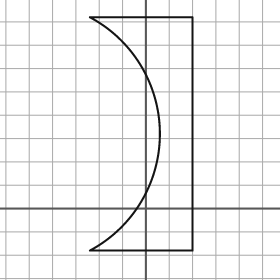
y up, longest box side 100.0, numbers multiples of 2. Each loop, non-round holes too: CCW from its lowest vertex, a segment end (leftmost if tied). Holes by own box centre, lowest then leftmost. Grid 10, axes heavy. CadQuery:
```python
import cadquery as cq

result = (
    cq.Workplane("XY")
    .moveTo(-24.0, -18.0)
    .lineTo(20.0, -18.0)
    .lineTo(20.0, 82.0)
    .lineTo(-24.0, 82.0)
    .threePointArc((6.0, 32.0), (-24.0, -18.0))
    .close()
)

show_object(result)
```